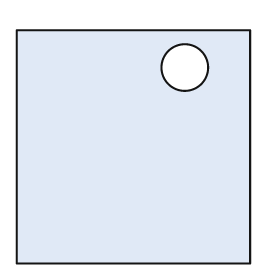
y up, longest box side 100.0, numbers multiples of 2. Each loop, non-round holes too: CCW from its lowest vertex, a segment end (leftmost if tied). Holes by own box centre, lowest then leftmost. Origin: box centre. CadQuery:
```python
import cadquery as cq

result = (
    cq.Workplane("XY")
    .moveTo(-50.0, -50.0)
    .lineTo(50.0, -50.0)
    .lineTo(50.0, 50.0)
    .lineTo(-50.0, 50.0)
    .close()
    .moveTo(22.0, 34.0)
    .circle(10.0)
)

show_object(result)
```